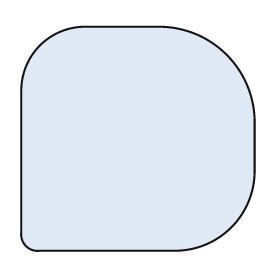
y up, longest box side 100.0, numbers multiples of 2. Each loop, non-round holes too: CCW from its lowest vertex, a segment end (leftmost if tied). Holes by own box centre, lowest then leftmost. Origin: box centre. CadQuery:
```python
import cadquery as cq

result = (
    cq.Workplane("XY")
    .moveTo(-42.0, -48.0)
    .lineTo(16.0, -48.0)
    .threePointArc((40.0, -38.0), (50.0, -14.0))
    .lineTo(50.0, 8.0)
    .threePointArc((38.0, 36.0), (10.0, 48.0))
    .lineTo(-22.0, 48.0)
    .threePointArc((-42.0, 40.0), (-50.0, 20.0))
    .lineTo(-50.0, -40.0)
    .threePointArc((-48.0, -46.0), (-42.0, -48.0))
    .close()
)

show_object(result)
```